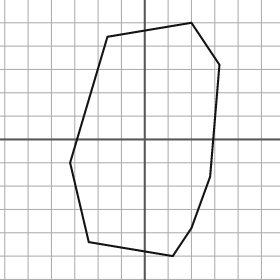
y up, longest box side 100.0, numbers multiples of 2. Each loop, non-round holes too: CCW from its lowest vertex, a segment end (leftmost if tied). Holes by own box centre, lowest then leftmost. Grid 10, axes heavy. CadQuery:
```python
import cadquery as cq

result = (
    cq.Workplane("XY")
    .moveTo(12.0, -50.0)
    .lineTo(20.0, -38.0)
    .lineTo(28.0, -16.0)
    .lineTo(32.0, 32.0)
    .lineTo(20.0, 50.0)
    .lineTo(-16.0, 44.0)
    .lineTo(-32.0, -10.0)
    .lineTo(-24.0, -44.0)
    .close()
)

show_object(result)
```